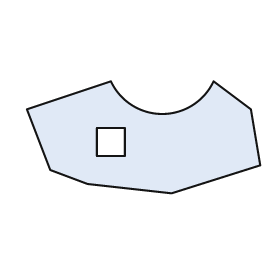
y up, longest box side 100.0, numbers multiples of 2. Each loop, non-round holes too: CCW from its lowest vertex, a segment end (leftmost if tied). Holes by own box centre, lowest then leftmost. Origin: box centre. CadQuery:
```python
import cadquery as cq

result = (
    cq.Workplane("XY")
    .moveTo(12.0, -24.0)
    .lineTo(50.0, -12.0)
    .lineTo(46.0, 12.0)
    .lineTo(30.0, 24.0)
    .threePointArc((8.0, 10.0), (-14.0, 24.0))
    .lineTo(-50.0, 12.0)
    .lineTo(-40.0, -14.0)
    .lineTo(-24.0, -20.0)
    .close()
    .moveTo(-20.0, -8.0)
    .lineTo(-8.0, -8.0)
    .lineTo(-8.0, 4.0)
    .lineTo(-20.0, 4.0)
    .close()
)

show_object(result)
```